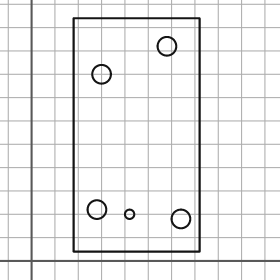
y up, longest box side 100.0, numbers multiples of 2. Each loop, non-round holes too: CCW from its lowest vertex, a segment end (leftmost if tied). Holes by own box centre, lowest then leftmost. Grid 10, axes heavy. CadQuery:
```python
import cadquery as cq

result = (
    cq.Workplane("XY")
    .moveTo(18.0, 4.0)
    .lineTo(72.0, 4.0)
    .lineTo(72.0, 104.0)
    .lineTo(18.0, 104.0)
    .close()
    .moveTo(64.0, 18.0)
    .circle(4.0)
    .moveTo(42.0, 20.0)
    .circle(2.0)
    .moveTo(28.0, 22.0)
    .circle(4.0)
    .moveTo(30.0, 80.0)
    .circle(4.0)
    .moveTo(58.0, 92.0)
    .circle(4.0)
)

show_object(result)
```